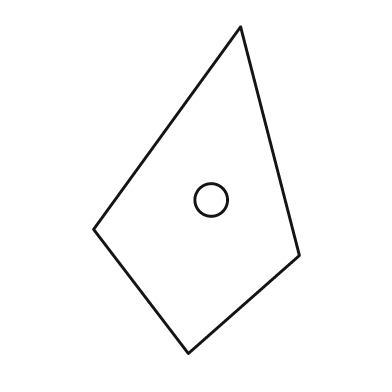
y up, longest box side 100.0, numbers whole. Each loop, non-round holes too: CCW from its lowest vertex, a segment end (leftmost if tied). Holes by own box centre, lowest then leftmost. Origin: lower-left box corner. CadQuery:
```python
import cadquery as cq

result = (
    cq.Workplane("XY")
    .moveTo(29.0, 0.0)
    .lineTo(63.0, 30.0)
    .lineTo(45.0, 100.0)
    .lineTo(0.0, 38.0)
    .close()
    .moveTo(36.0, 47.0)
    .circle(5.0)
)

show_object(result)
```